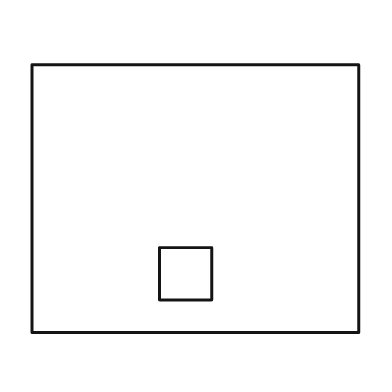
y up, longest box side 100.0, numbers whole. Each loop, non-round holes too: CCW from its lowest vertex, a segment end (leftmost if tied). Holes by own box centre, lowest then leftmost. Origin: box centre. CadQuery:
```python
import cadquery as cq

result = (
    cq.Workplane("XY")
    .moveTo(-50.0, -41.0)
    .lineTo(50.0, -41.0)
    .lineTo(50.0, 41.0)
    .lineTo(-50.0, 41.0)
    .close()
    .moveTo(-11.0, -31.0)
    .lineTo(5.0, -31.0)
    .lineTo(5.0, -15.0)
    .lineTo(-11.0, -15.0)
    .close()
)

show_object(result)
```